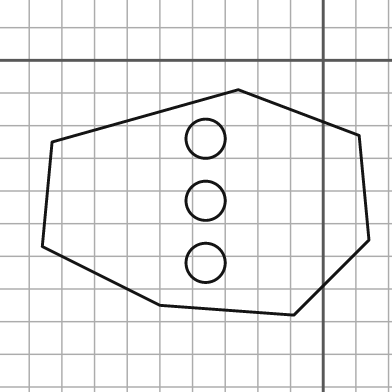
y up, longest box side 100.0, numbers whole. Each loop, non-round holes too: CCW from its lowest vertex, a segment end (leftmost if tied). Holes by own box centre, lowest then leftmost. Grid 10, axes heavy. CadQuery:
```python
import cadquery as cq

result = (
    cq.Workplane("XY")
    .moveTo(-9.0, -78.0)
    .lineTo(14.0, -55.0)
    .lineTo(11.0, -23.0)
    .lineTo(-26.0, -9.0)
    .lineTo(-83.0, -25.0)
    .lineTo(-86.0, -57.0)
    .lineTo(-50.0, -75.0)
    .close()
    .moveTo(-36.0, -62.0)
    .circle(6.0)
    .moveTo(-36.0, -43.0)
    .circle(6.0)
    .moveTo(-36.0, -24.0)
    .circle(6.0)
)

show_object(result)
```